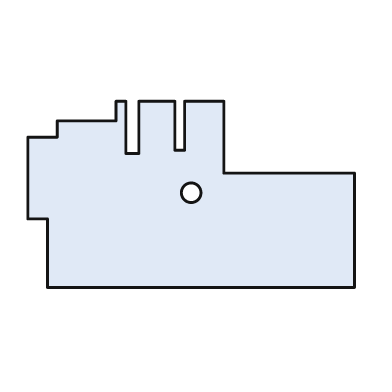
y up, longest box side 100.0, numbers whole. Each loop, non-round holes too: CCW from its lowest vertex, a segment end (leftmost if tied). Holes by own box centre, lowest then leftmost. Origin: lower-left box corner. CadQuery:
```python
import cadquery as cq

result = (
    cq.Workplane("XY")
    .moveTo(6.0, 0.0)
    .lineTo(100.0, 0.0)
    .lineTo(100.0, 35.0)
    .lineTo(60.0, 35.0)
    .lineTo(60.0, 57.0)
    .lineTo(48.0, 57.0)
    .lineTo(48.0, 42.0)
    .lineTo(45.0, 42.0)
    .lineTo(45.0, 57.0)
    .lineTo(34.0, 57.0)
    .lineTo(34.0, 41.0)
    .lineTo(30.0, 41.0)
    .lineTo(30.0, 57.0)
    .lineTo(27.0, 57.0)
    .lineTo(27.0, 51.0)
    .lineTo(9.0, 51.0)
    .lineTo(9.0, 46.0)
    .lineTo(0.0, 46.0)
    .lineTo(0.0, 21.0)
    .lineTo(6.0, 21.0)
    .close()
    .moveTo(50.0, 29.0)
    .circle(3.0)
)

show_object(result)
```